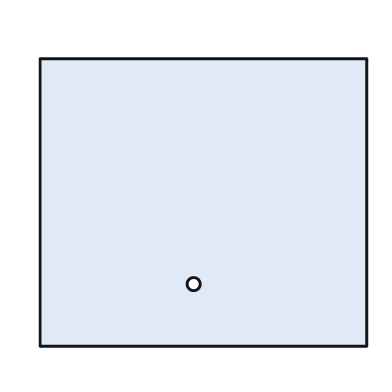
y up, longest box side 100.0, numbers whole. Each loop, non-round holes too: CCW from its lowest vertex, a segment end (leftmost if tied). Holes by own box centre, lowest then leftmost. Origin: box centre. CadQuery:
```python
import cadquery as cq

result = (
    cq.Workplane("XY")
    .moveTo(-50.0, -44.0)
    .lineTo(50.0, -44.0)
    .lineTo(50.0, 44.0)
    .lineTo(-50.0, 44.0)
    .close()
    .moveTo(-3.0, -25.0)
    .circle(2.0)
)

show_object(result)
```